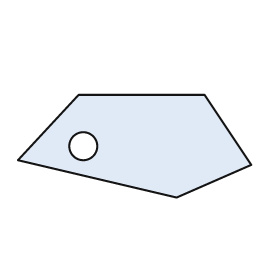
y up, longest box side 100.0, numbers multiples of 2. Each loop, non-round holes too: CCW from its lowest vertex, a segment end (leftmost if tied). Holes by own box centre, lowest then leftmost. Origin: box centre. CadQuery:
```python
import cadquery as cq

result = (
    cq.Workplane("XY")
    .moveTo(18.0, -22.0)
    .lineTo(50.0, -8.0)
    .lineTo(30.0, 22.0)
    .lineTo(-24.0, 22.0)
    .lineTo(-50.0, -6.0)
    .close()
    .moveTo(-22.0, 0.0)
    .circle(6.0)
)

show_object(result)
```